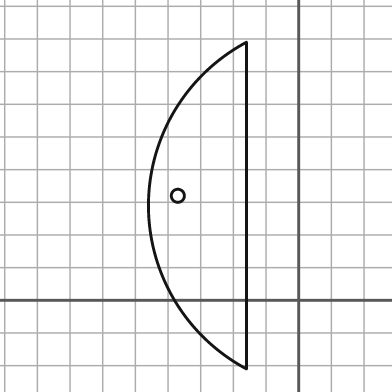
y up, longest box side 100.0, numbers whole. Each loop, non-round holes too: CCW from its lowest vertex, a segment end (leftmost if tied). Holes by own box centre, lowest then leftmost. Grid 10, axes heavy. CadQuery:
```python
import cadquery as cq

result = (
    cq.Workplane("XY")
    .moveTo(-16.0, -21.0)
    .lineTo(-16.0, 79.0)
    .threePointArc((-46.0, 29.0), (-16.0, -21.0))
    .close()
    .moveTo(-37.0, 32.0)
    .circle(2.0)
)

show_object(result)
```